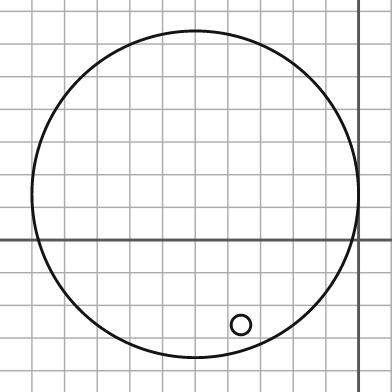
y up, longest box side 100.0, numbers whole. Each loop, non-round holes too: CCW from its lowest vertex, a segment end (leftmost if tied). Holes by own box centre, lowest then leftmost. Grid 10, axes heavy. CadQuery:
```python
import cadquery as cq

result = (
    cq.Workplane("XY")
    .moveTo(-50.0, 14.0)
    .circle(50.0)
    .moveTo(-36.0, -26.0)
    .circle(3.0)
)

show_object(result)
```